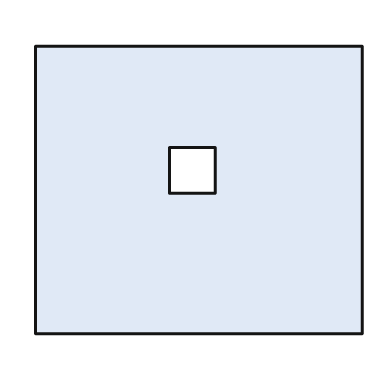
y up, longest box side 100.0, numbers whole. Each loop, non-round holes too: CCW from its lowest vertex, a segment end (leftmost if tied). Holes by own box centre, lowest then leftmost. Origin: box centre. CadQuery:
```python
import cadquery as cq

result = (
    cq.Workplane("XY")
    .moveTo(-50.0, -44.0)
    .lineTo(50.0, -44.0)
    .lineTo(50.0, 44.0)
    .lineTo(-50.0, 44.0)
    .close()
    .moveTo(-9.0, -1.0)
    .lineTo(5.0, -1.0)
    .lineTo(5.0, 13.0)
    .lineTo(-9.0, 13.0)
    .close()
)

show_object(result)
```